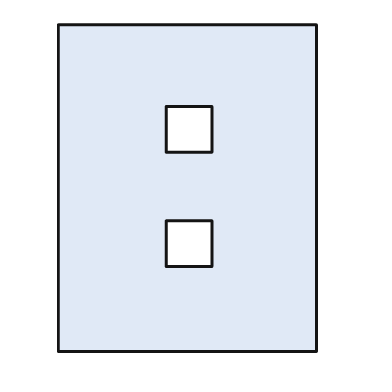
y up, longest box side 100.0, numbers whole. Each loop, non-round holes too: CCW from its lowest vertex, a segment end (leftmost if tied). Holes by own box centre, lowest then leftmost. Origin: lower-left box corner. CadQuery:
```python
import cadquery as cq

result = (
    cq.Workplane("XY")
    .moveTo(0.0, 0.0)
    .lineTo(79.0, 0.0)
    .lineTo(79.0, 100.0)
    .lineTo(0.0, 100.0)
    .close()
    .moveTo(33.0, 26.0)
    .lineTo(47.0, 26.0)
    .lineTo(47.0, 40.0)
    .lineTo(33.0, 40.0)
    .close()
    .moveTo(33.0, 61.0)
    .lineTo(47.0, 61.0)
    .lineTo(47.0, 75.0)
    .lineTo(33.0, 75.0)
    .close()
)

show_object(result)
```